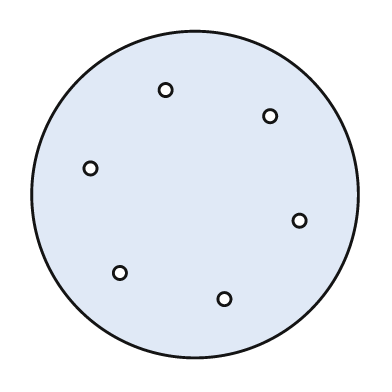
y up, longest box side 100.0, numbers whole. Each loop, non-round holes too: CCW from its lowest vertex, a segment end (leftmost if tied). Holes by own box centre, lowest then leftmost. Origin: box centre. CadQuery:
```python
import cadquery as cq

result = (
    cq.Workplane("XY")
    .moveTo(0.0, 0.0)
    .circle(50.0)
    .moveTo(9.0, -32.0)
    .circle(2.0)
    .moveTo(-23.0, -24.0)
    .circle(2.0)
    .moveTo(32.0, -8.0)
    .circle(2.0)
    .moveTo(-32.0, 8.0)
    .circle(2.0)
    .moveTo(23.0, 24.0)
    .circle(2.0)
    .moveTo(-9.0, 32.0)
    .circle(2.0)
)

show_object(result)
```